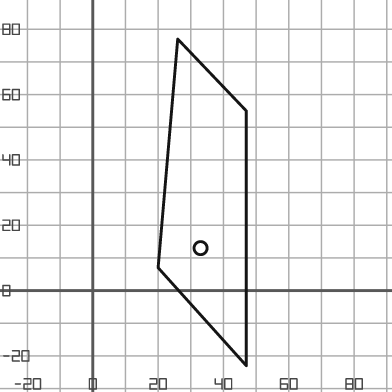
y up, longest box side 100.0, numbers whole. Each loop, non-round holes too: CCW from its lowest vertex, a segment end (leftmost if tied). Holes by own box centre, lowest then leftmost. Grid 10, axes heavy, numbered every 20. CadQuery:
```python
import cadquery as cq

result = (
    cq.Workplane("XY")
    .moveTo(47.0, -23.0)
    .lineTo(47.0, 55.0)
    .lineTo(26.0, 77.0)
    .lineTo(20.0, 7.0)
    .close()
    .moveTo(33.0, 13.0)
    .circle(2.0)
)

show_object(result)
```